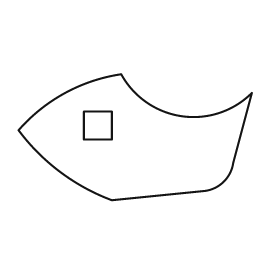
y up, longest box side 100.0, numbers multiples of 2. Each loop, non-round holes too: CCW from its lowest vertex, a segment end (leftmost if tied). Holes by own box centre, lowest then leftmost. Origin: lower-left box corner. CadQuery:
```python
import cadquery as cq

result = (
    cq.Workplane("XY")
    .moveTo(40.0, 0.0)
    .lineTo(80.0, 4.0)
    .threePointArc((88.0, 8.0), (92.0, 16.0))
    .lineTo(100.0, 46.0)
    .threePointArc((70.0, 36.0), (44.0, 54.0))
    .threePointArc((20.0, 46.0), (0.0, 30.0))
    .threePointArc((18.0, 12.0), (40.0, 0.0))
    .close()
    .moveTo(28.0, 26.0)
    .lineTo(40.0, 26.0)
    .lineTo(40.0, 38.0)
    .lineTo(28.0, 38.0)
    .close()
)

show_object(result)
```